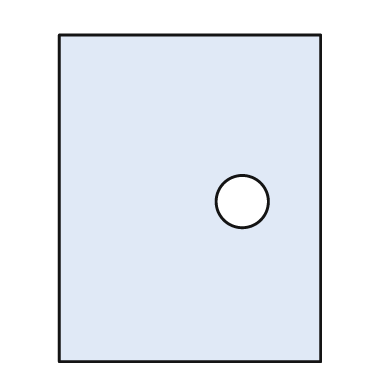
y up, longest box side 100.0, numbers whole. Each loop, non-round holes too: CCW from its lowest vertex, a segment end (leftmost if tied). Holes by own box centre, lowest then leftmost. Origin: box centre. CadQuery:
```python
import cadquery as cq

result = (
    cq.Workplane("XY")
    .moveTo(-40.0, -50.0)
    .lineTo(40.0, -50.0)
    .lineTo(40.0, 50.0)
    .lineTo(-40.0, 50.0)
    .close()
    .moveTo(16.0, -1.0)
    .circle(8.0)
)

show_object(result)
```